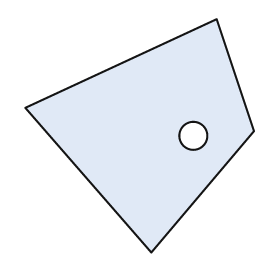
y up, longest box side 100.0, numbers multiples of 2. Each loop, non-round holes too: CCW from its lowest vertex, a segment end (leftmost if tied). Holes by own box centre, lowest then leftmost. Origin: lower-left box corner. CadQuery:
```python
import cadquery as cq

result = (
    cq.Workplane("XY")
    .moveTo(54.0, 0.0)
    .lineTo(98.0, 52.0)
    .lineTo(82.0, 100.0)
    .lineTo(0.0, 62.0)
    .close()
    .moveTo(72.0, 50.0)
    .circle(6.0)
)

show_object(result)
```